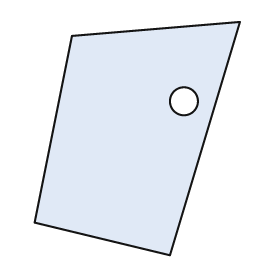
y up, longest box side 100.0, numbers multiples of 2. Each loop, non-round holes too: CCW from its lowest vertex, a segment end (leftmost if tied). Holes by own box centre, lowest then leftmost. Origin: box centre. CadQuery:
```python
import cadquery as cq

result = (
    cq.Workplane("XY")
    .moveTo(14.0, -50.0)
    .lineTo(44.0, 50.0)
    .lineTo(-28.0, 44.0)
    .lineTo(-44.0, -36.0)
    .close()
    .moveTo(20.0, 16.0)
    .circle(6.0)
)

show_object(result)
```